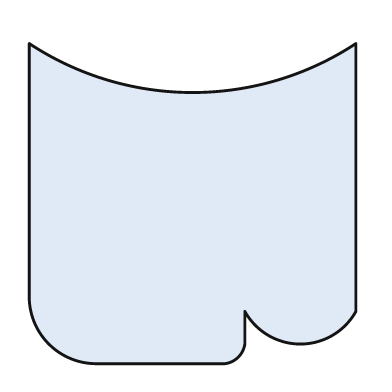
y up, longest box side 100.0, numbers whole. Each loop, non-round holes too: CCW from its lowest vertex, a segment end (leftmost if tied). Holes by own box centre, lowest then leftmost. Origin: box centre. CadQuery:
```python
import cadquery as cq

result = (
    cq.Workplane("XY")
    .moveTo(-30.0, -49.0)
    .lineTo(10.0, -49.0)
    .threePointArc((14.0, -47.0), (16.0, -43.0))
    .lineTo(16.0, -33.0)
    .threePointArc((33.0, -43.0), (50.0, -33.0))
    .lineTo(50.0, 49.0)
    .threePointArc((0.0, 34.0), (-50.0, 49.0))
    .lineTo(-50.0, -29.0)
    .threePointArc((-44.0, -43.0), (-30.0, -49.0))
    .close()
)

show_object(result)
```